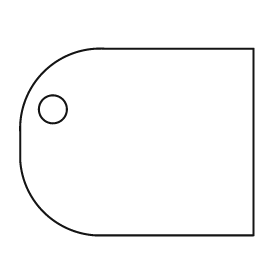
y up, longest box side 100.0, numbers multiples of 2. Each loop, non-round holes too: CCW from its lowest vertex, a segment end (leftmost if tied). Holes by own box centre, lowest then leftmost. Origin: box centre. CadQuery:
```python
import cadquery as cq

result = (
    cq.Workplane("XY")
    .moveTo(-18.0, -40.0)
    .lineTo(50.0, -40.0)
    .lineTo(50.0, 40.0)
    .lineTo(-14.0, 40.0)
    .threePointArc((-40.0, 30.0), (-50.0, 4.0))
    .lineTo(-50.0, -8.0)
    .threePointArc((-40.0, -30.0), (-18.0, -40.0))
    .close()
    .moveTo(-36.0, 14.0)
    .circle(6.0)
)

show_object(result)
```